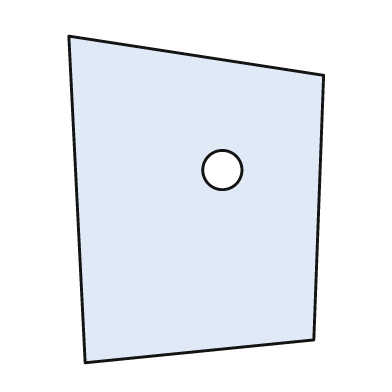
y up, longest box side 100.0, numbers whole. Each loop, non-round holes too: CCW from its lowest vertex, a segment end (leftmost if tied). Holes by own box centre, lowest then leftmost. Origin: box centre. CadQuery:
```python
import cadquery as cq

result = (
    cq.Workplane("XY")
    .moveTo(-34.0, -50.0)
    .lineTo(36.0, -43.0)
    .lineTo(39.0, 38.0)
    .lineTo(-39.0, 50.0)
    .close()
    .moveTo(8.0, 9.0)
    .circle(6.0)
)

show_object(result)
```